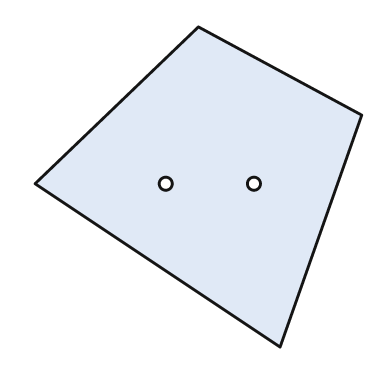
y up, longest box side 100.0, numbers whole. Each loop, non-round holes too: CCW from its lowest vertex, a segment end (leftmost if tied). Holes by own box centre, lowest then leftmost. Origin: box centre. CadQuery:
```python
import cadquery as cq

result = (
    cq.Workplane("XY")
    .moveTo(25.0, -49.0)
    .lineTo(50.0, 22.0)
    .lineTo(0.0, 49.0)
    .lineTo(-50.0, 1.0)
    .close()
    .moveTo(-10.0, 1.0)
    .circle(2.0)
    .moveTo(17.0, 1.0)
    .circle(2.0)
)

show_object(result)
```